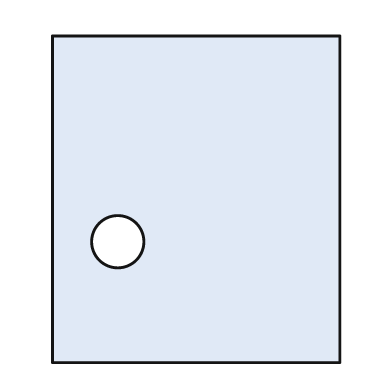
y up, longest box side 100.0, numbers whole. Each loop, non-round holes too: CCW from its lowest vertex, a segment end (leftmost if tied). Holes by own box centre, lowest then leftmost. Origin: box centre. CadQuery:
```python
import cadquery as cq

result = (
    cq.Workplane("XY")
    .moveTo(-44.0, -50.0)
    .lineTo(44.0, -50.0)
    .lineTo(44.0, 50.0)
    .lineTo(-44.0, 50.0)
    .close()
    .moveTo(-24.0, -13.0)
    .circle(8.0)
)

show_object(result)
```